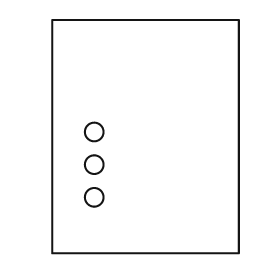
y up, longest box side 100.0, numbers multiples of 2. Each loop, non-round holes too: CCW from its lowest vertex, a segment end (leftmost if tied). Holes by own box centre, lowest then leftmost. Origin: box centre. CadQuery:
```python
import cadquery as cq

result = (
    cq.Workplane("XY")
    .moveTo(-40.0, -50.0)
    .lineTo(40.0, -50.0)
    .lineTo(40.0, 50.0)
    .lineTo(-40.0, 50.0)
    .close()
    .moveTo(-22.0, -26.0)
    .circle(4.0)
    .moveTo(-22.0, -12.0)
    .circle(4.0)
    .moveTo(-22.0, 2.0)
    .circle(4.0)
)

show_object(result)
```